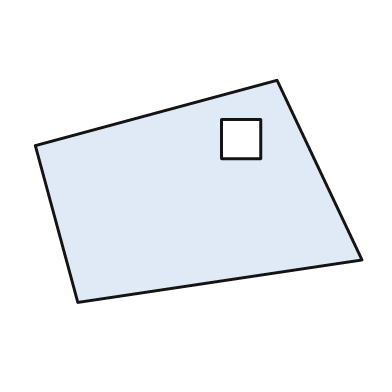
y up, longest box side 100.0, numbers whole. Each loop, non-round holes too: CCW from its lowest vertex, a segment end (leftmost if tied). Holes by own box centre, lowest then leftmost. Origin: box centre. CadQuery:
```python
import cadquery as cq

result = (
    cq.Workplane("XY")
    .moveTo(-37.0, -34.0)
    .lineTo(50.0, -21.0)
    .lineTo(24.0, 34.0)
    .lineTo(-50.0, 14.0)
    .close()
    .moveTo(7.0, 10.0)
    .lineTo(19.0, 10.0)
    .lineTo(19.0, 22.0)
    .lineTo(7.0, 22.0)
    .close()
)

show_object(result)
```